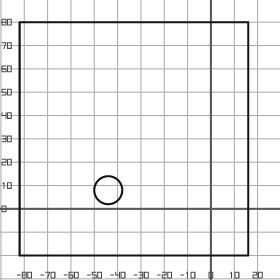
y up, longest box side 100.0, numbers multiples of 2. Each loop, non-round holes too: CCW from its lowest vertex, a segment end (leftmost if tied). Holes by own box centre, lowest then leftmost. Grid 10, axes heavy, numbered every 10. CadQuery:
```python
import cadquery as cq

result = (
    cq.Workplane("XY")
    .moveTo(-82.0, -20.0)
    .lineTo(16.0, -20.0)
    .lineTo(16.0, 80.0)
    .lineTo(-82.0, 80.0)
    .close()
    .moveTo(-44.0, 8.0)
    .circle(6.0)
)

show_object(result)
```